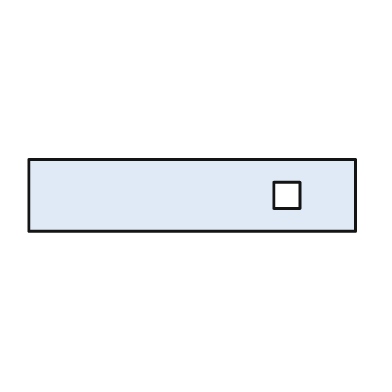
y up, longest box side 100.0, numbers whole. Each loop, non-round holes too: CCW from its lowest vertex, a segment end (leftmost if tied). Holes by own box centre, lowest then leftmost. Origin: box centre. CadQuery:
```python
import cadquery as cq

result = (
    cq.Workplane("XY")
    .moveTo(-50.0, -11.0)
    .lineTo(50.0, -11.0)
    .lineTo(50.0, 11.0)
    .lineTo(-50.0, 11.0)
    .close()
    .moveTo(25.0, -4.0)
    .lineTo(33.0, -4.0)
    .lineTo(33.0, 4.0)
    .lineTo(25.0, 4.0)
    .close()
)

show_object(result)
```